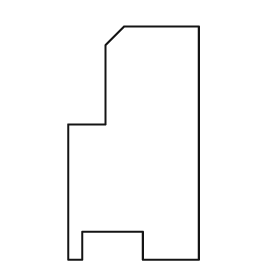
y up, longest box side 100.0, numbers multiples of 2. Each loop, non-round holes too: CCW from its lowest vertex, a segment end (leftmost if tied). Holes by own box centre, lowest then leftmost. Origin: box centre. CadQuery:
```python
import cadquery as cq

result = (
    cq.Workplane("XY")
    .moveTo(-28.0, -50.0)
    .lineTo(-22.0, -50.0)
    .lineTo(-22.0, -38.0)
    .lineTo(4.0, -38.0)
    .lineTo(4.0, -50.0)
    .lineTo(28.0, -50.0)
    .lineTo(28.0, 50.0)
    .lineTo(-4.0, 50.0)
    .lineTo(-12.0, 42.0)
    .lineTo(-12.0, 8.0)
    .lineTo(-28.0, 8.0)
    .close()
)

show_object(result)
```